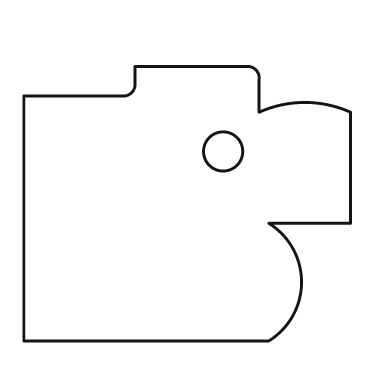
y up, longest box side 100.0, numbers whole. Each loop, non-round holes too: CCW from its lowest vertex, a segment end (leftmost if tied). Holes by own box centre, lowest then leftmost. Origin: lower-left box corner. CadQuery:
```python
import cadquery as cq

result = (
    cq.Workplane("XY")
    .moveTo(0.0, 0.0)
    .lineTo(75.0, 0.0)
    .threePointArc((85.0, 18.0), (75.0, 36.0))
    .lineTo(100.0, 36.0)
    .lineTo(100.0, 70.0)
    .threePointArc((86.0, 73.0), (72.0, 70.0))
    .lineTo(72.0, 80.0)
    .threePointArc((71.0, 83.0), (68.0, 84.0))
    .lineTo(34.0, 84.0)
    .lineTo(34.0, 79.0)
    .threePointArc((33.0, 76.0), (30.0, 75.0))
    .lineTo(0.0, 75.0)
    .close()
    .moveTo(61.0, 58.0)
    .circle(6.0)
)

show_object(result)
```